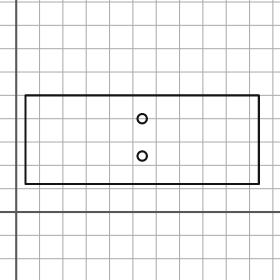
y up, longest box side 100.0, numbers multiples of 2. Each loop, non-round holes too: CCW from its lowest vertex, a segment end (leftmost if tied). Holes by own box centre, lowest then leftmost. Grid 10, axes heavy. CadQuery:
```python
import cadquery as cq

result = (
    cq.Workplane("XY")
    .moveTo(4.0, 12.0)
    .lineTo(104.0, 12.0)
    .lineTo(104.0, 50.0)
    .lineTo(4.0, 50.0)
    .close()
    .moveTo(54.0, 24.0)
    .circle(2.0)
    .moveTo(54.0, 40.0)
    .circle(2.0)
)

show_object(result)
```